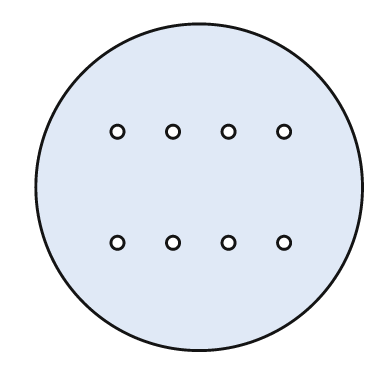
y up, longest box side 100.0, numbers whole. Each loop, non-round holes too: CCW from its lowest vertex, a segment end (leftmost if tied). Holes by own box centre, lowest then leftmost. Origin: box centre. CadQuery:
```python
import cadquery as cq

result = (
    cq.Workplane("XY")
    .moveTo(0.0, 0.0)
    .circle(50.0)
    .moveTo(-25.0, -17.0)
    .circle(2.0)
    .moveTo(-8.0, -17.0)
    .circle(2.0)
    .moveTo(9.0, -17.0)
    .circle(2.0)
    .moveTo(26.0, -17.0)
    .circle(2.0)
    .moveTo(-25.0, 17.0)
    .circle(2.0)
    .moveTo(-8.0, 17.0)
    .circle(2.0)
    .moveTo(9.0, 17.0)
    .circle(2.0)
    .moveTo(26.0, 17.0)
    .circle(2.0)
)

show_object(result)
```